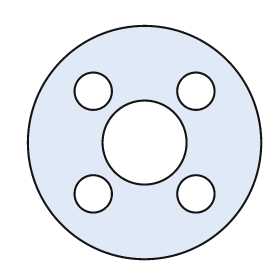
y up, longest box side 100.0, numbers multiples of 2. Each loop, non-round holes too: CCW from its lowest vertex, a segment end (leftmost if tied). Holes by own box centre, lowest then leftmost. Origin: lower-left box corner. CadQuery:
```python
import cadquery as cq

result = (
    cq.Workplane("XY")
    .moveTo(50.0, 50.0)
    .circle(50.0)
    .moveTo(28.0, 28.0)
    .circle(8.0)
    .moveTo(72.0, 28.0)
    .circle(8.0)
    .moveTo(50.0, 50.0)
    .circle(18.0)
    .moveTo(28.0, 72.0)
    .circle(8.0)
    .moveTo(72.0, 72.0)
    .circle(8.0)
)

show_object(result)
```